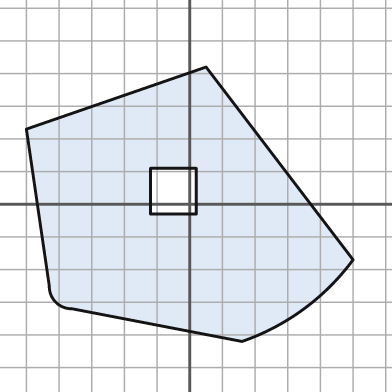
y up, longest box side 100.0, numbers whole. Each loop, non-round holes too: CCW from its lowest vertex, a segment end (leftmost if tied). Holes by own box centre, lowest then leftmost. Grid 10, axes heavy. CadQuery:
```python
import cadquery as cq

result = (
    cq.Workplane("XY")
    .moveTo(16.0, -42.0)
    .threePointArc((35.0, -32.0), (50.0, -17.0))
    .lineTo(5.0, 42.0)
    .lineTo(-50.0, 23.0)
    .lineTo(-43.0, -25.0)
    .threePointArc((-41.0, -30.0), (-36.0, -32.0))
    .close()
    .moveTo(-12.0, -3.0)
    .lineTo(2.0, -3.0)
    .lineTo(2.0, 11.0)
    .lineTo(-12.0, 11.0)
    .close()
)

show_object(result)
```